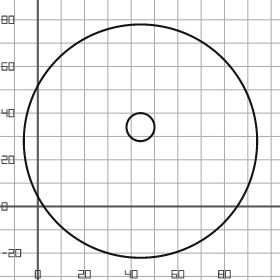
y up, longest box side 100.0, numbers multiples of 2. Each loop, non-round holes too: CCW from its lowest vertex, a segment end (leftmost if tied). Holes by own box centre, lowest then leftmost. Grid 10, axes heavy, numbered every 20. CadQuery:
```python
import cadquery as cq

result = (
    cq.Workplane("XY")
    .moveTo(44.0, 28.0)
    .circle(50.0)
    .moveTo(44.0, 34.0)
    .circle(6.0)
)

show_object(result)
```